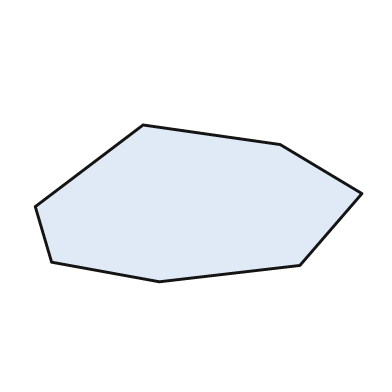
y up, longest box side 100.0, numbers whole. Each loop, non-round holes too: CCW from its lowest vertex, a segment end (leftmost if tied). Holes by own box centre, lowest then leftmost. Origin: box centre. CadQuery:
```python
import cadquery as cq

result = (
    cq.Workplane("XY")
    .moveTo(-12.0, -24.0)
    .lineTo(31.0, -19.0)
    .lineTo(50.0, 3.0)
    .lineTo(25.0, 18.0)
    .lineTo(-17.0, 24.0)
    .lineTo(-50.0, -1.0)
    .lineTo(-45.0, -18.0)
    .close()
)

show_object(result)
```